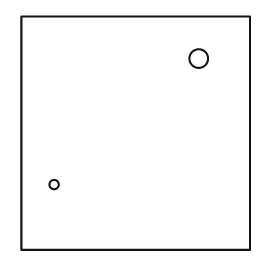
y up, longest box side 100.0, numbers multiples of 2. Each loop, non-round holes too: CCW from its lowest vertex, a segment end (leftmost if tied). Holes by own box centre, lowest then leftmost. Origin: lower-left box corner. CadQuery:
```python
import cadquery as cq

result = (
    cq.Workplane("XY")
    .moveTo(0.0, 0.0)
    .lineTo(98.0, 0.0)
    .lineTo(98.0, 100.0)
    .lineTo(0.0, 100.0)
    .close()
    .moveTo(14.0, 28.0)
    .circle(2.0)
    .moveTo(76.0, 82.0)
    .circle(4.0)
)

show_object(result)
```